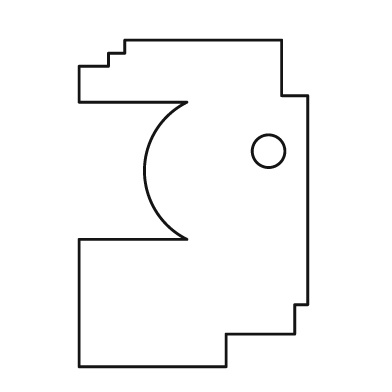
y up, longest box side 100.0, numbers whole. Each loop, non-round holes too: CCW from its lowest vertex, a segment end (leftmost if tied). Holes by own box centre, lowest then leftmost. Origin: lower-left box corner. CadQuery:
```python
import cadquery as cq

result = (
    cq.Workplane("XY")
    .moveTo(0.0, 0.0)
    .lineTo(45.0, 0.0)
    .lineTo(45.0, 10.0)
    .lineTo(66.0, 10.0)
    .lineTo(66.0, 19.0)
    .lineTo(70.0, 19.0)
    .lineTo(70.0, 83.0)
    .lineTo(62.0, 83.0)
    .lineTo(62.0, 100.0)
    .lineTo(14.0, 100.0)
    .lineTo(14.0, 96.0)
    .lineTo(9.0, 96.0)
    .lineTo(9.0, 92.0)
    .lineTo(0.0, 92.0)
    .lineTo(0.0, 81.0)
    .lineTo(33.0, 81.0)
    .threePointArc((20.0, 60.0), (33.0, 39.0))
    .lineTo(0.0, 39.0)
    .close()
    .moveTo(58.0, 66.0)
    .circle(5.0)
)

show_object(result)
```